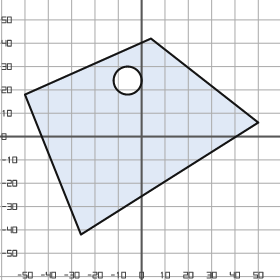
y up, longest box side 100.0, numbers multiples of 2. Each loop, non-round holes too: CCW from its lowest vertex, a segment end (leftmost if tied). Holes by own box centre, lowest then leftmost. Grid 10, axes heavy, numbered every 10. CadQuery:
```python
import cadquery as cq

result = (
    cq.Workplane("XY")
    .moveTo(-26.0, -42.0)
    .lineTo(50.0, 6.0)
    .lineTo(4.0, 42.0)
    .lineTo(-50.0, 18.0)
    .close()
    .moveTo(-6.0, 24.0)
    .circle(6.0)
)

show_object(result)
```